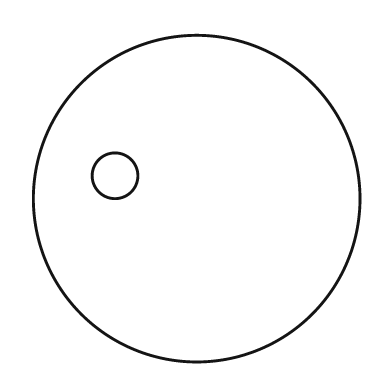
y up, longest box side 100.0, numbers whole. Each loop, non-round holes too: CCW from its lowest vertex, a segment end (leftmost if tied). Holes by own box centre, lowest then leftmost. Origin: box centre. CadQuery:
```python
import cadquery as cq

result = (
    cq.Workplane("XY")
    .moveTo(0.0, 0.0)
    .circle(50.0)
    .moveTo(-25.0, 7.0)
    .circle(7.0)
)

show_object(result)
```